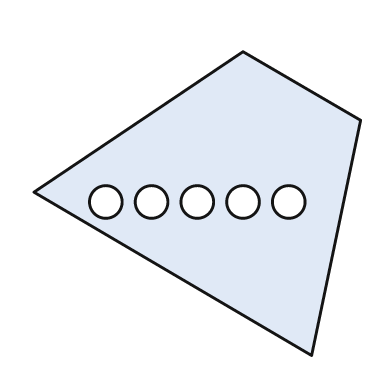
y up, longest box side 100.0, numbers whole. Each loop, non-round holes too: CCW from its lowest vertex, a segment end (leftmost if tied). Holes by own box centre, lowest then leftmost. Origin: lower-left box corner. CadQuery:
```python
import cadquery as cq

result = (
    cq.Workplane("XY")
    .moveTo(85.0, 0.0)
    .lineTo(100.0, 72.0)
    .lineTo(64.0, 93.0)
    .lineTo(0.0, 50.0)
    .close()
    .moveTo(22.0, 47.0)
    .circle(5.0)
    .moveTo(36.0, 47.0)
    .circle(5.0)
    .moveTo(50.0, 47.0)
    .circle(5.0)
    .moveTo(64.0, 47.0)
    .circle(5.0)
    .moveTo(78.0, 47.0)
    .circle(5.0)
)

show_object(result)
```